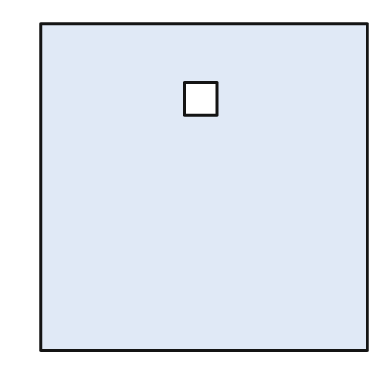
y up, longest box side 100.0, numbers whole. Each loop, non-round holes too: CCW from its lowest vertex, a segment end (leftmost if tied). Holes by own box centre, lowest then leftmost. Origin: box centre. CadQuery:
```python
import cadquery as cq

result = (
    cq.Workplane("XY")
    .moveTo(-50.0, -50.0)
    .lineTo(50.0, -50.0)
    .lineTo(50.0, 50.0)
    .lineTo(-50.0, 50.0)
    .close()
    .moveTo(-6.0, 22.0)
    .lineTo(4.0, 22.0)
    .lineTo(4.0, 32.0)
    .lineTo(-6.0, 32.0)
    .close()
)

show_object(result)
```